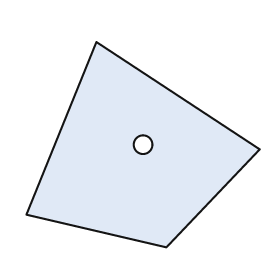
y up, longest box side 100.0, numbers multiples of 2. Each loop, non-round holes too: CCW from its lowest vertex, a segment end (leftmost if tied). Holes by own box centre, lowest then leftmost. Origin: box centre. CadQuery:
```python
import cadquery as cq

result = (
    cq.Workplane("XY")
    .moveTo(10.0, -44.0)
    .lineTo(50.0, -2.0)
    .lineTo(-20.0, 44.0)
    .lineTo(-50.0, -30.0)
    .close()
    .moveTo(0.0, 0.0)
    .circle(4.0)
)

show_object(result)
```